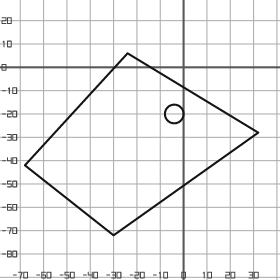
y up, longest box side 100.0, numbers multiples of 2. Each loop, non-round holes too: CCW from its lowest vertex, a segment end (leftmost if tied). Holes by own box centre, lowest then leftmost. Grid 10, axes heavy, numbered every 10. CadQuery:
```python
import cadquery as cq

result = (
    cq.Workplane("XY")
    .moveTo(-30.0, -72.0)
    .lineTo(32.0, -28.0)
    .lineTo(-24.0, 6.0)
    .lineTo(-68.0, -42.0)
    .close()
    .moveTo(-4.0, -20.0)
    .circle(4.0)
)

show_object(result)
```